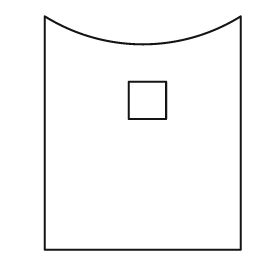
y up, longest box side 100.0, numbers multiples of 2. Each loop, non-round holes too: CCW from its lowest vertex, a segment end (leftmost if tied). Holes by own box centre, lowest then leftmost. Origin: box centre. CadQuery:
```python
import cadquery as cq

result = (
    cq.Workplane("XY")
    .moveTo(-42.0, -50.0)
    .lineTo(42.0, -50.0)
    .lineTo(42.0, 50.0)
    .threePointArc((0.0, 38.0), (-42.0, 50.0))
    .close()
    .moveTo(-6.0, 6.0)
    .lineTo(10.0, 6.0)
    .lineTo(10.0, 22.0)
    .lineTo(-6.0, 22.0)
    .close()
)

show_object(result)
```